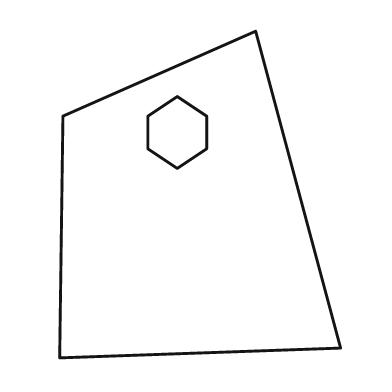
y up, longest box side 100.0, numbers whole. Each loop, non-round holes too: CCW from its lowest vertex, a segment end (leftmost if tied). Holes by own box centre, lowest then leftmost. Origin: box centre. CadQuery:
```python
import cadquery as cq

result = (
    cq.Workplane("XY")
    .moveTo(-43.0, -50.0)
    .lineTo(43.0, -47.0)
    .lineTo(17.0, 50.0)
    .lineTo(-42.0, 24.0)
    .close()
    .moveTo(-7.0, 8.0)
    .lineTo(2.0, 14.0)
    .lineTo(2.0, 24.0)
    .lineTo(-7.0, 30.0)
    .lineTo(-16.0, 24.0)
    .lineTo(-16.0, 14.0)
    .close()
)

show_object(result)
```